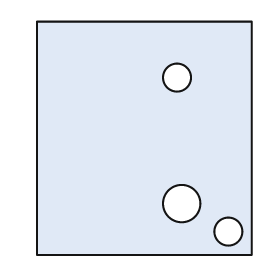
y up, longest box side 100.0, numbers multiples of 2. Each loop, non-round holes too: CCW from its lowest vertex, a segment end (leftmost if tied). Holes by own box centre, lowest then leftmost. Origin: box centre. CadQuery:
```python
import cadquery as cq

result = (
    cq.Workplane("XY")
    .moveTo(-46.0, -50.0)
    .lineTo(46.0, -50.0)
    .lineTo(46.0, 50.0)
    .lineTo(-46.0, 50.0)
    .close()
    .moveTo(36.0, -40.0)
    .circle(6.0)
    .moveTo(16.0, -28.0)
    .circle(8.0)
    .moveTo(14.0, 26.0)
    .circle(6.0)
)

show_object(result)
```